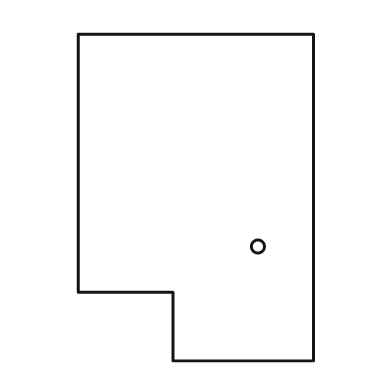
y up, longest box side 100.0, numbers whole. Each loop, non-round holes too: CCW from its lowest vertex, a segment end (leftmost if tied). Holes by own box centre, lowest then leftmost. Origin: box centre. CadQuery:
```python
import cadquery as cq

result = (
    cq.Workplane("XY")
    .moveTo(-7.0, -50.0)
    .lineTo(36.0, -50.0)
    .lineTo(36.0, 50.0)
    .lineTo(-36.0, 50.0)
    .lineTo(-36.0, -29.0)
    .lineTo(-7.0, -29.0)
    .close()
    .moveTo(19.0, -15.0)
    .circle(2.0)
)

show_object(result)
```